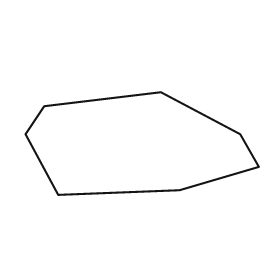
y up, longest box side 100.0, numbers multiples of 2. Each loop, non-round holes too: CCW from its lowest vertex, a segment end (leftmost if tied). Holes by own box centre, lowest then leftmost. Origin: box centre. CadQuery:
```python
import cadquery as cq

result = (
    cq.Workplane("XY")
    .moveTo(-36.0, -22.0)
    .lineTo(16.0, -20.0)
    .lineTo(50.0, -10.0)
    .lineTo(42.0, 4.0)
    .lineTo(8.0, 22.0)
    .lineTo(-42.0, 16.0)
    .lineTo(-50.0, 4.0)
    .close()
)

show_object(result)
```